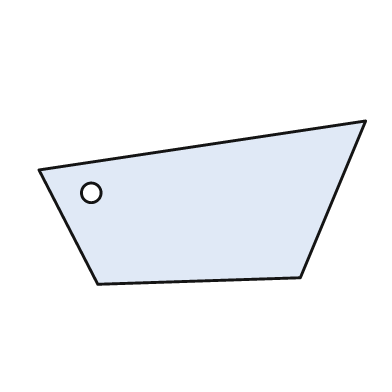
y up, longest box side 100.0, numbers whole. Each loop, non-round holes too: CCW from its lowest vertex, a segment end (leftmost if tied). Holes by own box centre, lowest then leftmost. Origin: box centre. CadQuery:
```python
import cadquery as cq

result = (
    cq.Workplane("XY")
    .moveTo(-32.0, -25.0)
    .lineTo(30.0, -23.0)
    .lineTo(50.0, 25.0)
    .lineTo(-50.0, 10.0)
    .close()
    .moveTo(-34.0, 3.0)
    .circle(3.0)
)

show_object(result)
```